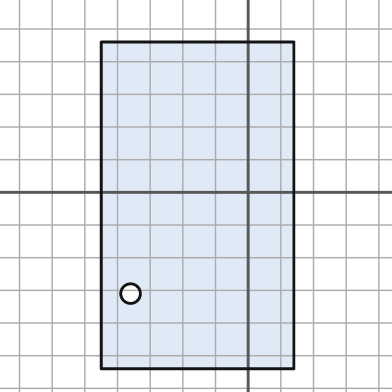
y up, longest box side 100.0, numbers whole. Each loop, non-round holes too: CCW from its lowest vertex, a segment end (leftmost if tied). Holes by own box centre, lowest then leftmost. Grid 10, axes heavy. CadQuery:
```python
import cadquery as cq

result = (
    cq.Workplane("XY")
    .moveTo(-45.0, -54.0)
    .lineTo(14.0, -54.0)
    .lineTo(14.0, 46.0)
    .lineTo(-45.0, 46.0)
    .close()
    .moveTo(-36.0, -31.0)
    .circle(3.0)
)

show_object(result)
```